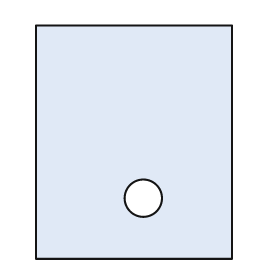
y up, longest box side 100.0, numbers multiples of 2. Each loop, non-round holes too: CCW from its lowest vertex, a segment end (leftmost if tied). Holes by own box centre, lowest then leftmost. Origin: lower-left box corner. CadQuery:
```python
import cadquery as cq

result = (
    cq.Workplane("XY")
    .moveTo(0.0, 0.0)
    .lineTo(84.0, 0.0)
    .lineTo(84.0, 100.0)
    .lineTo(0.0, 100.0)
    .close()
    .moveTo(46.0, 26.0)
    .circle(8.0)
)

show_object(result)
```